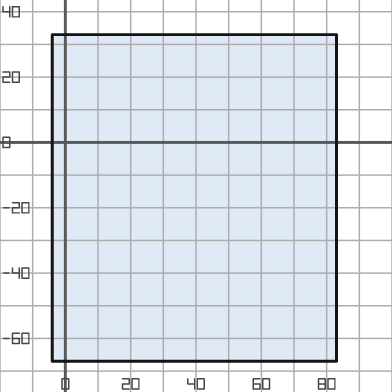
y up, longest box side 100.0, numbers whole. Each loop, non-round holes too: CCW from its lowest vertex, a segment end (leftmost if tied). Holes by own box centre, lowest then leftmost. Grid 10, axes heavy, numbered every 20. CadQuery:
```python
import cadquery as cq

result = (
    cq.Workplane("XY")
    .moveTo(-4.0, -67.0)
    .lineTo(83.0, -67.0)
    .lineTo(83.0, 33.0)
    .lineTo(-4.0, 33.0)
    .close()
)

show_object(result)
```